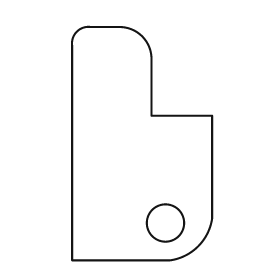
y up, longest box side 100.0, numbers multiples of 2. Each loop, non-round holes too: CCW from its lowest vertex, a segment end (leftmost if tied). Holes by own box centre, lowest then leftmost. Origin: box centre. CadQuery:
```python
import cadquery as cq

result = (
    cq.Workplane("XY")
    .moveTo(-30.0, -50.0)
    .lineTo(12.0, -50.0)
    .threePointArc((24.0, -44.0), (30.0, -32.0))
    .lineTo(30.0, 12.0)
    .lineTo(4.0, 12.0)
    .lineTo(4.0, 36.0)
    .threePointArc((0.0, 46.0), (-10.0, 50.0))
    .lineTo(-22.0, 50.0)
    .threePointArc((-28.0, 48.0), (-30.0, 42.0))
    .close()
    .moveTo(10.0, -34.0)
    .circle(8.0)
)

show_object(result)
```